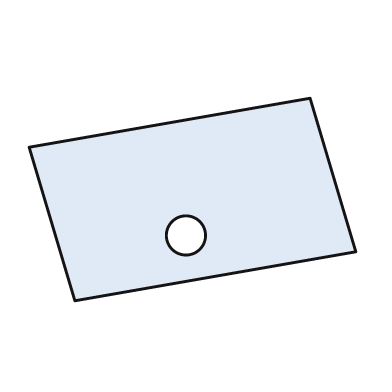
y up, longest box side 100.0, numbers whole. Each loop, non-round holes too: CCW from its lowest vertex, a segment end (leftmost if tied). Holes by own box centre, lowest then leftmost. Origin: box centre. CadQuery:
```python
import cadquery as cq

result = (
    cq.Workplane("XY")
    .moveTo(-36.0, -31.0)
    .lineTo(50.0, -16.0)
    .lineTo(36.0, 31.0)
    .lineTo(-50.0, 16.0)
    .close()
    .moveTo(-2.0, -11.0)
    .circle(6.0)
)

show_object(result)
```